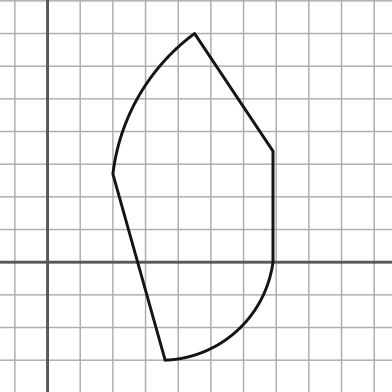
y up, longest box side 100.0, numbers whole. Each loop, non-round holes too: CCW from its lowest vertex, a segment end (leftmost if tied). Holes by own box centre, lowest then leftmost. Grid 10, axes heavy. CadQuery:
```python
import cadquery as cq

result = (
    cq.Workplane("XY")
    .moveTo(36.0, -30.0)
    .threePointArc((58.0, -21.0), (69.0, 0.0))
    .lineTo(69.0, 34.0)
    .lineTo(45.0, 70.0)
    .threePointArc((28.0, 51.0), (20.0, 27.0))
    .close()
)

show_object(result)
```